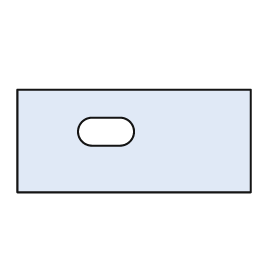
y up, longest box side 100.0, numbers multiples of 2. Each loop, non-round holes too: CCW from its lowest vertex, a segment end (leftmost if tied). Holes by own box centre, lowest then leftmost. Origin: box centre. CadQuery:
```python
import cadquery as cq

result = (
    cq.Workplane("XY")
    .moveTo(-50.0, -22.0)
    .lineTo(50.0, -22.0)
    .lineTo(50.0, 22.0)
    .lineTo(-50.0, 22.0)
    .close()
    .moveTo(-18.0, -2.0)
    .lineTo(-6.0, -2.0)
    .threePointArc((0.0, 4.0), (-6.0, 10.0))
    .lineTo(-18.0, 10.0)
    .threePointArc((-24.0, 4.0), (-18.0, -2.0))
    .close()
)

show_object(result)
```